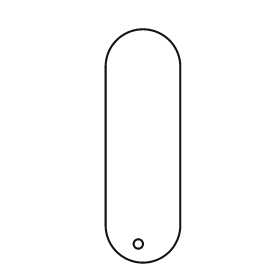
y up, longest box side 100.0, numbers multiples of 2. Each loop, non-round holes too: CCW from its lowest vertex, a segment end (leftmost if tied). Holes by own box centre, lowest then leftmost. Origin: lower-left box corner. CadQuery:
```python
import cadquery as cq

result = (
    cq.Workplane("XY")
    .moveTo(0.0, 16.0)
    .threePointArc((16.0, 0.0), (32.0, 16.0))
    .lineTo(32.0, 84.0)
    .threePointArc((16.0, 100.0), (0.0, 84.0))
    .close()
    .moveTo(14.0, 8.0)
    .circle(2.0)
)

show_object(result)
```